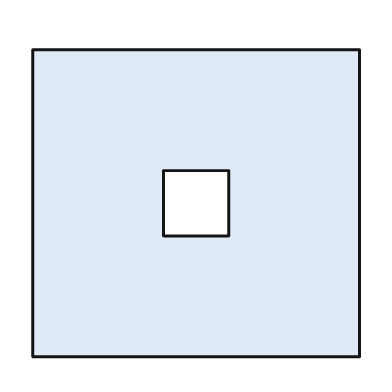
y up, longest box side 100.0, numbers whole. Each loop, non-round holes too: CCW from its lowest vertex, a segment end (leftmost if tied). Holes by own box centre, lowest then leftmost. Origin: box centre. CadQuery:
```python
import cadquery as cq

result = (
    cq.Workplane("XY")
    .moveTo(-50.0, -47.0)
    .lineTo(50.0, -47.0)
    .lineTo(50.0, 47.0)
    .lineTo(-50.0, 47.0)
    .close()
    .moveTo(-10.0, -10.0)
    .lineTo(10.0, -10.0)
    .lineTo(10.0, 10.0)
    .lineTo(-10.0, 10.0)
    .close()
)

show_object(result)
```